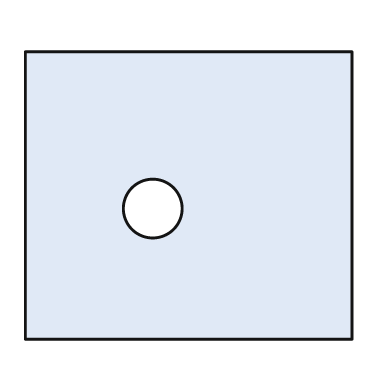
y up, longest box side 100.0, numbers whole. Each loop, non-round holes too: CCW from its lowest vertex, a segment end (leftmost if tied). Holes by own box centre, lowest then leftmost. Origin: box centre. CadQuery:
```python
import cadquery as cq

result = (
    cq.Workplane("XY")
    .moveTo(-50.0, -44.0)
    .lineTo(50.0, -44.0)
    .lineTo(50.0, 44.0)
    .lineTo(-50.0, 44.0)
    .close()
    .moveTo(-11.0, -4.0)
    .circle(9.0)
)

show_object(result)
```